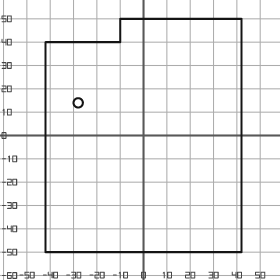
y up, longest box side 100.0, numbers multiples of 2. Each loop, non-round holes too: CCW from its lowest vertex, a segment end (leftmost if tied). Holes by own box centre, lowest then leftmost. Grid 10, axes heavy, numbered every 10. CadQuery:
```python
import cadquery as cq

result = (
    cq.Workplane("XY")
    .moveTo(-42.0, -50.0)
    .lineTo(42.0, -50.0)
    .lineTo(42.0, 50.0)
    .lineTo(-10.0, 50.0)
    .lineTo(-10.0, 40.0)
    .lineTo(-42.0, 40.0)
    .close()
    .moveTo(-28.0, 14.0)
    .circle(2.0)
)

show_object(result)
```